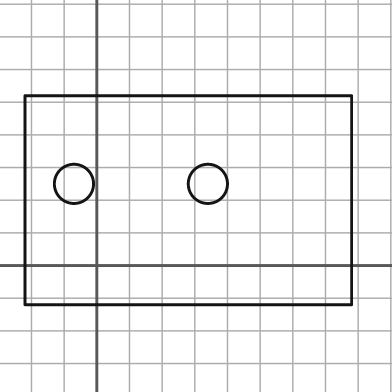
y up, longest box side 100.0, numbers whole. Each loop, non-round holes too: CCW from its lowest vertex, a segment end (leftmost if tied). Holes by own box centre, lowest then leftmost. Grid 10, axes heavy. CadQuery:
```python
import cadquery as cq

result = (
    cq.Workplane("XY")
    .moveTo(-22.0, -12.0)
    .lineTo(78.0, -12.0)
    .lineTo(78.0, 52.0)
    .lineTo(-22.0, 52.0)
    .close()
    .moveTo(-7.0, 25.0)
    .circle(6.0)
    .moveTo(34.0, 25.0)
    .circle(6.0)
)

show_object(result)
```